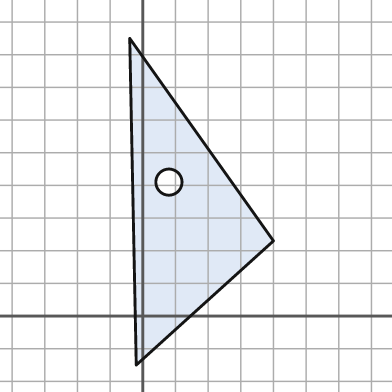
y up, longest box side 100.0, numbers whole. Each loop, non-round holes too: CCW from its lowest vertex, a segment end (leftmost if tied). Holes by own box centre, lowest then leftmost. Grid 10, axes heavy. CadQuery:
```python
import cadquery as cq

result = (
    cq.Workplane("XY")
    .moveTo(-2.0, -15.0)
    .lineTo(40.0, 23.0)
    .lineTo(-4.0, 85.0)
    .close()
    .moveTo(8.0, 41.0)
    .circle(4.0)
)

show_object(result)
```